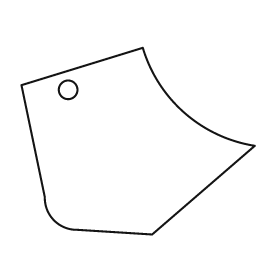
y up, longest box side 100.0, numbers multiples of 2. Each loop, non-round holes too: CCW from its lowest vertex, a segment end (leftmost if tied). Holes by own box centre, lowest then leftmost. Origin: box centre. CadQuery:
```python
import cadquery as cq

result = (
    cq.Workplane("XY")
    .moveTo(6.0, -40.0)
    .lineTo(50.0, -2.0)
    .threePointArc((20.0, 12.0), (2.0, 40.0))
    .lineTo(-50.0, 24.0)
    .lineTo(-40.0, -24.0)
    .threePointArc((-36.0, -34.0), (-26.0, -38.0))
    .close()
    .moveTo(-30.0, 22.0)
    .circle(4.0)
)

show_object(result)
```